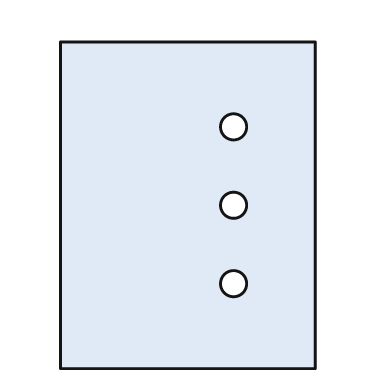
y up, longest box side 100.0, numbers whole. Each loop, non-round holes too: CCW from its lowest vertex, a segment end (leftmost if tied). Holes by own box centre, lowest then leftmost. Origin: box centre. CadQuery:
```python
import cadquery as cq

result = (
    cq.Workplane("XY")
    .moveTo(-39.0, -50.0)
    .lineTo(39.0, -50.0)
    .lineTo(39.0, 50.0)
    .lineTo(-39.0, 50.0)
    .close()
    .moveTo(14.0, -24.0)
    .circle(4.0)
    .moveTo(14.0, 0.0)
    .circle(4.0)
    .moveTo(14.0, 24.0)
    .circle(4.0)
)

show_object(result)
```